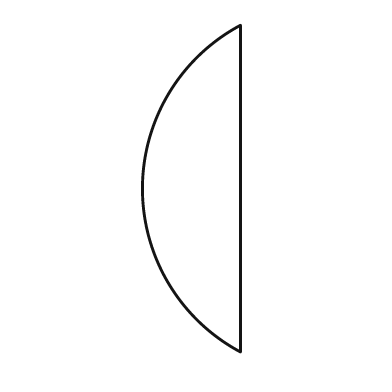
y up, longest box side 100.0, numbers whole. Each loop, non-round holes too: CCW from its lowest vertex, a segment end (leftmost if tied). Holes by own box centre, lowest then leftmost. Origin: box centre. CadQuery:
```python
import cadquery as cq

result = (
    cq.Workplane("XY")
    .moveTo(15.0, -50.0)
    .lineTo(15.0, 50.0)
    .threePointArc((-15.0, 0.0), (15.0, -50.0))
    .close()
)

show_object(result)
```